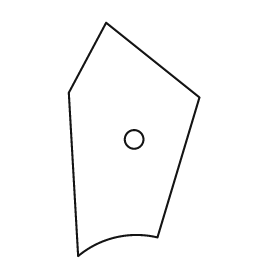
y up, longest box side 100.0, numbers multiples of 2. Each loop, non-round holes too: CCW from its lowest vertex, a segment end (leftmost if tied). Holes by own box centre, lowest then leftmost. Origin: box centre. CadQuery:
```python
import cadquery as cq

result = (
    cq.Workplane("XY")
    .moveTo(-24.0, -50.0)
    .threePointArc((-8.0, -42.0), (10.0, -42.0))
    .lineTo(28.0, 18.0)
    .lineTo(-12.0, 50.0)
    .lineTo(-28.0, 20.0)
    .close()
    .moveTo(0.0, 0.0)
    .circle(4.0)
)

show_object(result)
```